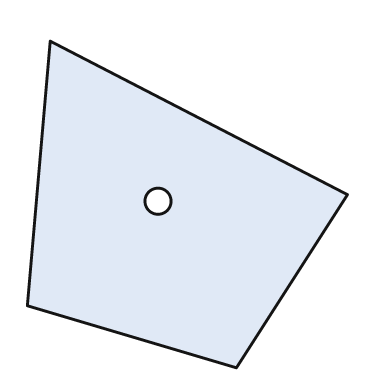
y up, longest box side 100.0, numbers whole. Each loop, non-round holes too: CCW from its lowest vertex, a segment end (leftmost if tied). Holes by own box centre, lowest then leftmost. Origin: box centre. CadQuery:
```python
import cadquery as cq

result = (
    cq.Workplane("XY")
    .moveTo(15.0, -50.0)
    .lineTo(49.0, 3.0)
    .lineTo(-42.0, 50.0)
    .lineTo(-49.0, -31.0)
    .close()
    .moveTo(-9.0, 1.0)
    .circle(4.0)
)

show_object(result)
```